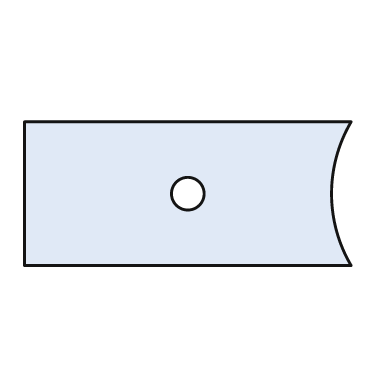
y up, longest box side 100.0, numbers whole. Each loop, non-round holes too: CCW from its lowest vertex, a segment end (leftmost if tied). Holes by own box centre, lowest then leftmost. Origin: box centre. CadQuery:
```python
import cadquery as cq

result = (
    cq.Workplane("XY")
    .moveTo(-50.0, -22.0)
    .lineTo(50.0, -22.0)
    .threePointArc((44.0, 0.0), (50.0, 22.0))
    .lineTo(-50.0, 22.0)
    .close()
    .moveTo(0.0, 0.0)
    .circle(5.0)
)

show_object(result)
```